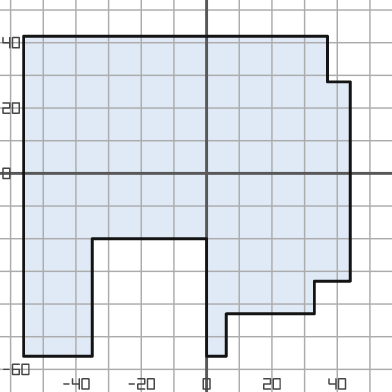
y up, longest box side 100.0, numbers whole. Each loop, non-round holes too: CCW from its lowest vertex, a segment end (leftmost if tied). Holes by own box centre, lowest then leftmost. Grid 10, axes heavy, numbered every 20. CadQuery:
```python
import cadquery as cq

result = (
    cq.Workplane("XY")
    .moveTo(-56.0, -56.0)
    .lineTo(-35.0, -56.0)
    .lineTo(-35.0, -20.0)
    .lineTo(0.0, -20.0)
    .lineTo(0.0, -56.0)
    .lineTo(6.0, -56.0)
    .lineTo(6.0, -43.0)
    .lineTo(33.0, -43.0)
    .lineTo(33.0, -33.0)
    .lineTo(44.0, -33.0)
    .lineTo(44.0, 28.0)
    .lineTo(37.0, 28.0)
    .lineTo(37.0, 42.0)
    .lineTo(-56.0, 42.0)
    .close()
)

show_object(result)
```